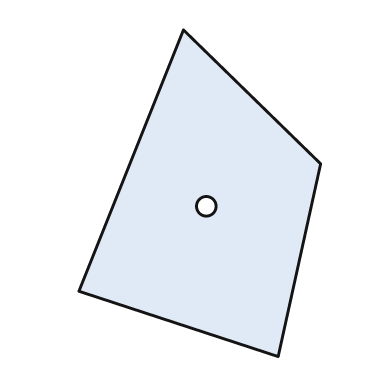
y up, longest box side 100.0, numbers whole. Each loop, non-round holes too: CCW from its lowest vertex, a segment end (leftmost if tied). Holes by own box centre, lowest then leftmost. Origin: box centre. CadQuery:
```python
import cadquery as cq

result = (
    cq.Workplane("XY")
    .moveTo(24.0, -50.0)
    .lineTo(37.0, 9.0)
    .lineTo(-5.0, 50.0)
    .lineTo(-37.0, -30.0)
    .close()
    .moveTo(2.0, -4.0)
    .circle(3.0)
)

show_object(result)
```